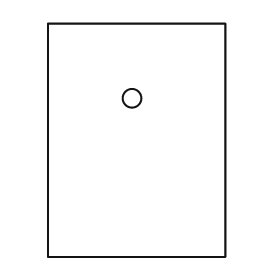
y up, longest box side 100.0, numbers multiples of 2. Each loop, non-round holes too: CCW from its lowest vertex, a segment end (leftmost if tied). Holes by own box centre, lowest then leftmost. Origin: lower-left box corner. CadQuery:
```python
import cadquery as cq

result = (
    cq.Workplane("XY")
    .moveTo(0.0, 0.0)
    .lineTo(76.0, 0.0)
    .lineTo(76.0, 100.0)
    .lineTo(0.0, 100.0)
    .close()
    .moveTo(36.0, 68.0)
    .circle(4.0)
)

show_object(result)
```